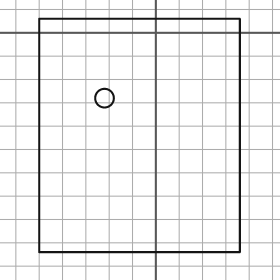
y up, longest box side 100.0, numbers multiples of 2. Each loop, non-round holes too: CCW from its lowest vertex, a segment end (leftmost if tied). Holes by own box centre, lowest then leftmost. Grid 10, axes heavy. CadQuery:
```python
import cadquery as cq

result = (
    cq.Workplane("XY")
    .moveTo(-50.0, -94.0)
    .lineTo(36.0, -94.0)
    .lineTo(36.0, 6.0)
    .lineTo(-50.0, 6.0)
    .close()
    .moveTo(-22.0, -28.0)
    .circle(4.0)
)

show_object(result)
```